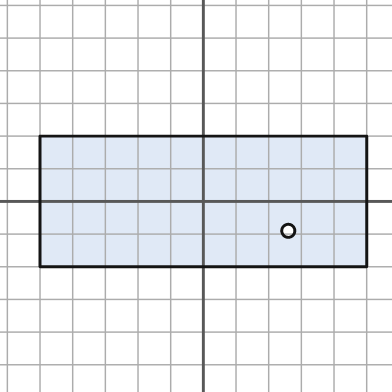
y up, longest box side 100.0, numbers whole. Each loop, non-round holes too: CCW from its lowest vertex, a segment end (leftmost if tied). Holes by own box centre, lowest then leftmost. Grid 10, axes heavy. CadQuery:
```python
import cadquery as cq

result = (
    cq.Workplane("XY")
    .moveTo(-50.0, -20.0)
    .lineTo(50.0, -20.0)
    .lineTo(50.0, 20.0)
    .lineTo(-50.0, 20.0)
    .close()
    .moveTo(26.0, -9.0)
    .circle(2.0)
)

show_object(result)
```